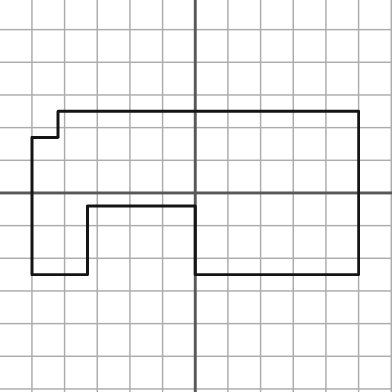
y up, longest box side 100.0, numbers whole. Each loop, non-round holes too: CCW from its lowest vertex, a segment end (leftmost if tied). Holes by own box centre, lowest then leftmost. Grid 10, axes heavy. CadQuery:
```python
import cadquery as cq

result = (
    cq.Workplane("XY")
    .moveTo(-50.0, -25.0)
    .lineTo(-33.0, -25.0)
    .lineTo(-33.0, -4.0)
    .lineTo(0.0, -4.0)
    .lineTo(0.0, -25.0)
    .lineTo(50.0, -25.0)
    .lineTo(50.0, 25.0)
    .lineTo(-42.0, 25.0)
    .lineTo(-42.0, 17.0)
    .lineTo(-50.0, 17.0)
    .close()
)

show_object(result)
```